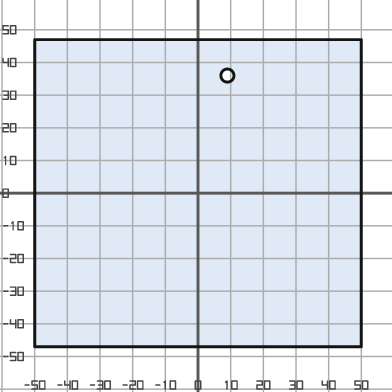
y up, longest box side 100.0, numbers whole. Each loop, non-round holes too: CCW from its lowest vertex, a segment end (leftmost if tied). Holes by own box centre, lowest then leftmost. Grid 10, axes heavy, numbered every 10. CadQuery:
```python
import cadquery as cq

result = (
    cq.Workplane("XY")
    .moveTo(-50.0, -47.0)
    .lineTo(50.0, -47.0)
    .lineTo(50.0, 47.0)
    .lineTo(-50.0, 47.0)
    .close()
    .moveTo(9.0, 36.0)
    .circle(2.0)
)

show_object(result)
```